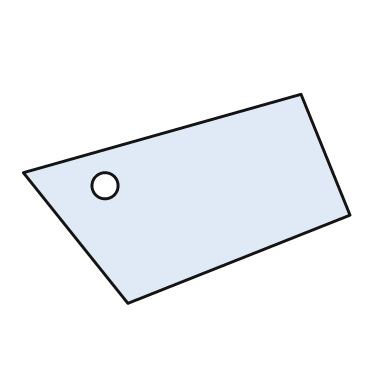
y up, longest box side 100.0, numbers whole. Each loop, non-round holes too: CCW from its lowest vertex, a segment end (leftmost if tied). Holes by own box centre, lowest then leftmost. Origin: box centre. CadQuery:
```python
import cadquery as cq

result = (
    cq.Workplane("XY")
    .moveTo(-18.0, -32.0)
    .lineTo(50.0, -5.0)
    .lineTo(35.0, 32.0)
    .lineTo(-50.0, 8.0)
    .close()
    .moveTo(-25.0, 4.0)
    .circle(4.0)
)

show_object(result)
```